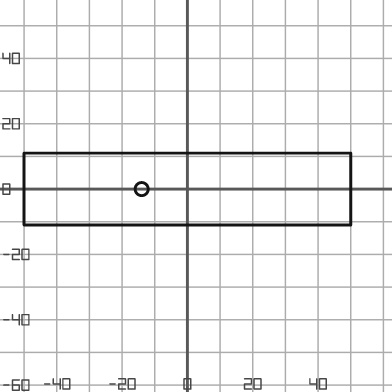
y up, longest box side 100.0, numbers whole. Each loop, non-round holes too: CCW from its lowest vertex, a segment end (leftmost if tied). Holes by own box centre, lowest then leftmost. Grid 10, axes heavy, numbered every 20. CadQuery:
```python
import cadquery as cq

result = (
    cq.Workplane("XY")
    .moveTo(-50.0, -11.0)
    .lineTo(50.0, -11.0)
    .lineTo(50.0, 11.0)
    .lineTo(-50.0, 11.0)
    .close()
    .moveTo(-14.0, 0.0)
    .circle(2.0)
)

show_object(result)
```